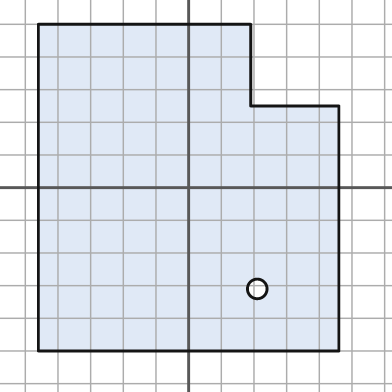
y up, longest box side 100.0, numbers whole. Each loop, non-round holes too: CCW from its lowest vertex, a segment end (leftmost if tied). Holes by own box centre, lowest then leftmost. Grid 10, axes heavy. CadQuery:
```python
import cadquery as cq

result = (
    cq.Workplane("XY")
    .moveTo(-46.0, -50.0)
    .lineTo(46.0, -50.0)
    .lineTo(46.0, 25.0)
    .lineTo(19.0, 25.0)
    .lineTo(19.0, 50.0)
    .lineTo(-46.0, 50.0)
    .close()
    .moveTo(21.0, -31.0)
    .circle(3.0)
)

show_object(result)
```